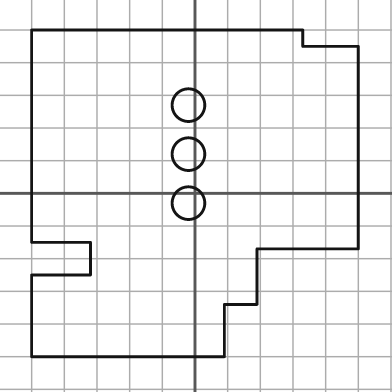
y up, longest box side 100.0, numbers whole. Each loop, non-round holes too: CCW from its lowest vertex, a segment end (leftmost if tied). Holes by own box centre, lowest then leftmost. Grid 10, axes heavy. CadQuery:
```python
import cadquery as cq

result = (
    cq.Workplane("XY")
    .moveTo(-50.0, -50.0)
    .lineTo(9.0, -50.0)
    .lineTo(9.0, -34.0)
    .lineTo(19.0, -34.0)
    .lineTo(19.0, -17.0)
    .lineTo(50.0, -17.0)
    .lineTo(50.0, 45.0)
    .lineTo(33.0, 45.0)
    .lineTo(33.0, 50.0)
    .lineTo(-50.0, 50.0)
    .lineTo(-50.0, -15.0)
    .lineTo(-32.0, -15.0)
    .lineTo(-32.0, -25.0)
    .lineTo(-50.0, -25.0)
    .close()
    .moveTo(-2.0, -3.0)
    .circle(5.0)
    .moveTo(-2.0, 12.0)
    .circle(5.0)
    .moveTo(-2.0, 27.0)
    .circle(5.0)
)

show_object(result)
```